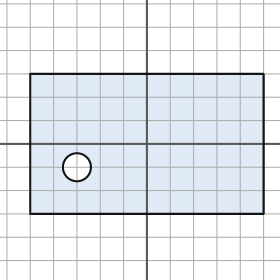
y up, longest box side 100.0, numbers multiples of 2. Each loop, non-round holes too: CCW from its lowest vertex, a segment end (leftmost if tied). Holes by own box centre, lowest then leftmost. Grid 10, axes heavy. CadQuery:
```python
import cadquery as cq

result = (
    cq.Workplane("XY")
    .moveTo(-50.0, -30.0)
    .lineTo(50.0, -30.0)
    .lineTo(50.0, 30.0)
    .lineTo(-50.0, 30.0)
    .close()
    .moveTo(-30.0, -10.0)
    .circle(6.0)
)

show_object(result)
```